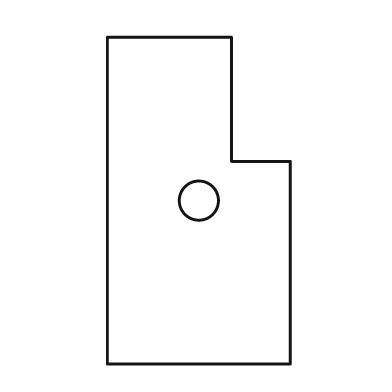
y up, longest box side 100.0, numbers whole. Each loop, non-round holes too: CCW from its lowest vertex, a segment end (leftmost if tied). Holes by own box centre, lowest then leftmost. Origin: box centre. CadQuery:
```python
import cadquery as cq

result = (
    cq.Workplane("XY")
    .moveTo(-28.0, -50.0)
    .lineTo(28.0, -50.0)
    .lineTo(28.0, 12.0)
    .lineTo(10.0, 12.0)
    .lineTo(10.0, 50.0)
    .lineTo(-28.0, 50.0)
    .close()
    .moveTo(0.0, 0.0)
    .circle(6.0)
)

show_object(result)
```